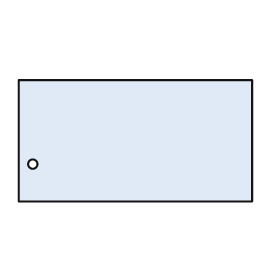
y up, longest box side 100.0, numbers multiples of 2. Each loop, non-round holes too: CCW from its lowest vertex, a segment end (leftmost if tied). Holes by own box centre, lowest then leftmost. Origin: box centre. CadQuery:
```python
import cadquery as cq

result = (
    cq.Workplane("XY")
    .moveTo(-50.0, -26.0)
    .lineTo(50.0, -26.0)
    .lineTo(50.0, 26.0)
    .lineTo(-50.0, 26.0)
    .close()
    .moveTo(-44.0, -10.0)
    .circle(2.0)
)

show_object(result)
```